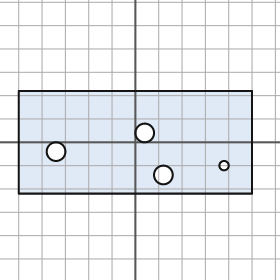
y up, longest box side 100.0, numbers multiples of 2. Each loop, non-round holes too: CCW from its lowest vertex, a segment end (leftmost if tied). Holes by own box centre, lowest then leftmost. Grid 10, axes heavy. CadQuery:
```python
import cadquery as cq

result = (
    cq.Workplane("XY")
    .moveTo(-50.0, -22.0)
    .lineTo(50.0, -22.0)
    .lineTo(50.0, 22.0)
    .lineTo(-50.0, 22.0)
    .close()
    .moveTo(12.0, -14.0)
    .circle(4.0)
    .moveTo(38.0, -10.0)
    .circle(2.0)
    .moveTo(-34.0, -4.0)
    .circle(4.0)
    .moveTo(4.0, 4.0)
    .circle(4.0)
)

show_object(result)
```